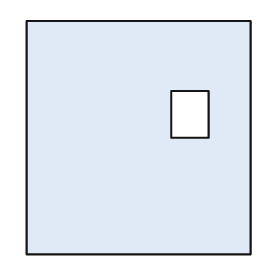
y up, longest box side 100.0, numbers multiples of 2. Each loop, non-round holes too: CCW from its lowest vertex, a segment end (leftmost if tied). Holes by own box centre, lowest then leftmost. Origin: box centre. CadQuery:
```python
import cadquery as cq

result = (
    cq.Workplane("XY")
    .moveTo(-48.0, -50.0)
    .lineTo(48.0, -50.0)
    .lineTo(48.0, 50.0)
    .lineTo(-48.0, 50.0)
    .close()
    .moveTo(14.0, 0.0)
    .lineTo(30.0, 0.0)
    .lineTo(30.0, 20.0)
    .lineTo(14.0, 20.0)
    .close()
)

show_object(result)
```